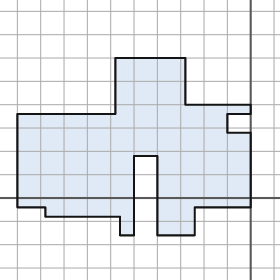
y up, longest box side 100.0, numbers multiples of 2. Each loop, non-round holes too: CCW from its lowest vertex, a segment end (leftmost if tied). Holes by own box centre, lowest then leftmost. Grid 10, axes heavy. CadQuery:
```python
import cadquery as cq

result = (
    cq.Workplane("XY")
    .moveTo(-56.0, -16.0)
    .lineTo(-50.0, -16.0)
    .lineTo(-50.0, 18.0)
    .lineTo(-40.0, 18.0)
    .lineTo(-40.0, -16.0)
    .lineTo(-24.0, -16.0)
    .lineTo(-24.0, -4.0)
    .lineTo(0.0, -4.0)
    .lineTo(0.0, 28.0)
    .lineTo(-10.0, 28.0)
    .lineTo(-10.0, 36.0)
    .lineTo(0.0, 36.0)
    .lineTo(0.0, 40.0)
    .lineTo(-28.0, 40.0)
    .lineTo(-28.0, 60.0)
    .lineTo(-58.0, 60.0)
    .lineTo(-58.0, 36.0)
    .lineTo(-100.0, 36.0)
    .lineTo(-100.0, -4.0)
    .lineTo(-88.0, -4.0)
    .lineTo(-88.0, -8.0)
    .lineTo(-56.0, -8.0)
    .close()
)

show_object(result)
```